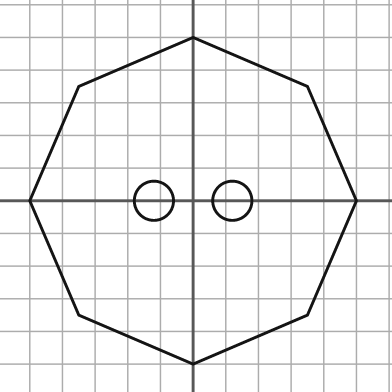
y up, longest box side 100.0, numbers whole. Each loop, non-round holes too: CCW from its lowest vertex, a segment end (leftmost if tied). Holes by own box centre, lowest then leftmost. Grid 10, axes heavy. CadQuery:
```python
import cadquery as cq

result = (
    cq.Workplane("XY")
    .moveTo(0.0, -50.0)
    .lineTo(35.0, -35.0)
    .lineTo(50.0, 0.0)
    .lineTo(35.0, 35.0)
    .lineTo(0.0, 50.0)
    .lineTo(-35.0, 35.0)
    .lineTo(-50.0, 0.0)
    .lineTo(-35.0, -35.0)
    .close()
    .moveTo(-12.0, 0.0)
    .circle(6.0)
    .moveTo(12.0, 0.0)
    .circle(6.0)
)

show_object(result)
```